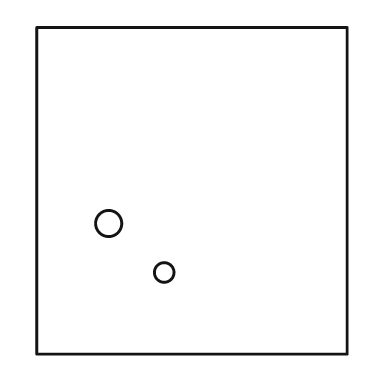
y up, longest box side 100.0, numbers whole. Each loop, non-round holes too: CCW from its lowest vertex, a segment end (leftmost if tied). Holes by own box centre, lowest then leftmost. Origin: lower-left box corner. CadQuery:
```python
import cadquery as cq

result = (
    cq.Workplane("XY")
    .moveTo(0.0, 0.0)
    .lineTo(95.0, 0.0)
    .lineTo(95.0, 100.0)
    .lineTo(0.0, 100.0)
    .close()
    .moveTo(39.0, 25.0)
    .circle(3.0)
    .moveTo(22.0, 40.0)
    .circle(4.0)
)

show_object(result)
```